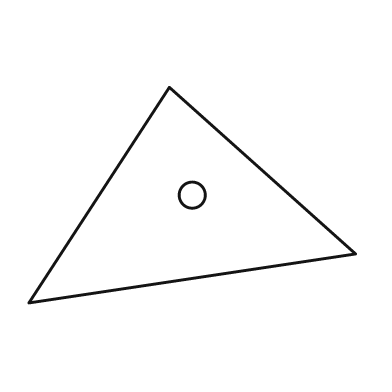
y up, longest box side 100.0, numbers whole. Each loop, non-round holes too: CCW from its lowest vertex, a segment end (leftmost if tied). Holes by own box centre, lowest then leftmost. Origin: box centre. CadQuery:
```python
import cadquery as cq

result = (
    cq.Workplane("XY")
    .moveTo(-50.0, -33.0)
    .lineTo(50.0, -18.0)
    .lineTo(-7.0, 33.0)
    .close()
    .moveTo(0.0, 0.0)
    .circle(4.0)
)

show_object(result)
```